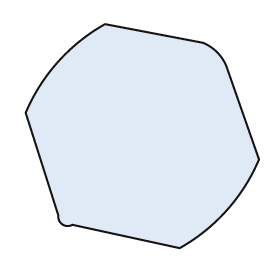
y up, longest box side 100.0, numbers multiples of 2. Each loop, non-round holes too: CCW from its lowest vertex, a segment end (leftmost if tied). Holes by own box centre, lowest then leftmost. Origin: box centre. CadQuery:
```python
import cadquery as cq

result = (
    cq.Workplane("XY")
    .moveTo(16.0, -48.0)
    .threePointArc((36.0, -32.0), (50.0, -10.0))
    .lineTo(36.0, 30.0)
    .threePointArc((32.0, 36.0), (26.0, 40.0))
    .lineTo(-16.0, 48.0)
    .threePointArc((-36.0, 32.0), (-50.0, 10.0))
    .lineTo(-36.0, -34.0)
    .threePointArc((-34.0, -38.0), (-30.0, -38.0))
    .close()
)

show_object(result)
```